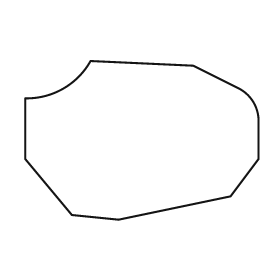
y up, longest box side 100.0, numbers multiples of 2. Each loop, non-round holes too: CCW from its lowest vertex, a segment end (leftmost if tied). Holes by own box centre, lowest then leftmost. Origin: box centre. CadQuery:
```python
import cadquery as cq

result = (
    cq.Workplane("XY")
    .moveTo(-10.0, -34.0)
    .lineTo(38.0, -24.0)
    .lineTo(50.0, -8.0)
    .lineTo(50.0, 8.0)
    .threePointArc((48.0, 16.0), (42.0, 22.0))
    .lineTo(22.0, 32.0)
    .lineTo(-22.0, 34.0)
    .threePointArc((-34.0, 22.0), (-50.0, 18.0))
    .lineTo(-50.0, -8.0)
    .lineTo(-30.0, -32.0)
    .close()
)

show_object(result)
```